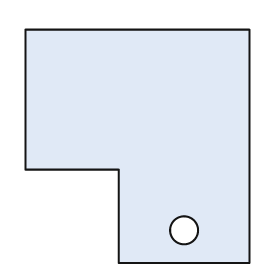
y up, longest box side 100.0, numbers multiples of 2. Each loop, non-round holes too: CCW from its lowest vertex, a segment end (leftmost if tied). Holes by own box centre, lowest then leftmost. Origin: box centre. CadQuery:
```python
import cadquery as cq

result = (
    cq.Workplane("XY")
    .moveTo(-8.0, -50.0)
    .lineTo(48.0, -50.0)
    .lineTo(48.0, 50.0)
    .lineTo(-48.0, 50.0)
    .lineTo(-48.0, -10.0)
    .lineTo(-8.0, -10.0)
    .close()
    .moveTo(20.0, -36.0)
    .circle(6.0)
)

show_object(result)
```